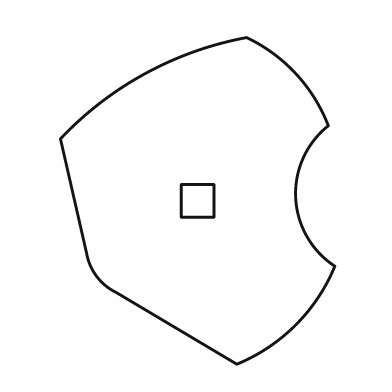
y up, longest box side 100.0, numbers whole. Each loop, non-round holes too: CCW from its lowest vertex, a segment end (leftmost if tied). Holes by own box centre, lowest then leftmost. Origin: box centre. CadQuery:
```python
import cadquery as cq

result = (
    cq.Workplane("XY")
    .moveTo(12.0, -50.0)
    .threePointArc((30.0, -38.0), (42.0, -20.0))
    .threePointArc((30.0, 1.0), (40.0, 23.0))
    .threePointArc((30.0, 39.0), (15.0, 50.0))
    .threePointArc((-16.0, 39.0), (-42.0, 19.0))
    .lineTo(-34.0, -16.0)
    .threePointArc((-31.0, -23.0), (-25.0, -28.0))
    .close()
    .moveTo(-5.0, -5.0)
    .lineTo(5.0, -5.0)
    .lineTo(5.0, 5.0)
    .lineTo(-5.0, 5.0)
    .close()
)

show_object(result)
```